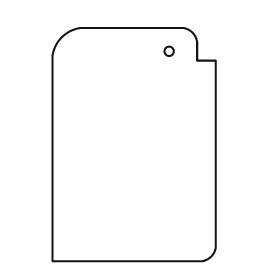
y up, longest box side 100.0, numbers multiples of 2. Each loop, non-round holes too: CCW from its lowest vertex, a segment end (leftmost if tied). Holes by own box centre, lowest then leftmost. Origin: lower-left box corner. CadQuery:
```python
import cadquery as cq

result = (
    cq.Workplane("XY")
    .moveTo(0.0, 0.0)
    .lineTo(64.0, 0.0)
    .threePointArc((68.0, 2.0), (70.0, 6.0))
    .lineTo(70.0, 86.0)
    .lineTo(62.0, 86.0)
    .lineTo(62.0, 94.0)
    .threePointArc((60.0, 98.0), (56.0, 100.0))
    .lineTo(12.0, 100.0)
    .threePointArc((4.0, 96.0), (0.0, 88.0))
    .close()
    .moveTo(50.0, 90.0)
    .circle(2.0)
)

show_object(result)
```